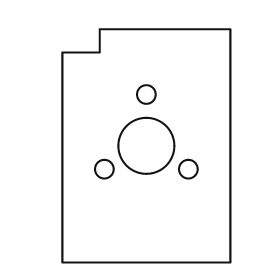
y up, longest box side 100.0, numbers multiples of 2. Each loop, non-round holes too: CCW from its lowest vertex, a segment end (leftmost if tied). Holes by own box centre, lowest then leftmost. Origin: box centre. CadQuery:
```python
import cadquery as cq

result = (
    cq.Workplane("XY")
    .moveTo(-36.0, -50.0)
    .lineTo(36.0, -50.0)
    .lineTo(36.0, 50.0)
    .lineTo(-20.0, 50.0)
    .lineTo(-20.0, 40.0)
    .lineTo(-36.0, 40.0)
    .close()
    .moveTo(-18.0, -10.0)
    .circle(4.0)
    .moveTo(18.0, -10.0)
    .circle(4.0)
    .moveTo(0.0, 0.0)
    .circle(12.0)
    .moveTo(0.0, 22.0)
    .circle(4.0)
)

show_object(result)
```